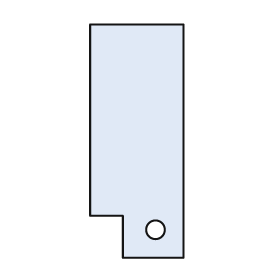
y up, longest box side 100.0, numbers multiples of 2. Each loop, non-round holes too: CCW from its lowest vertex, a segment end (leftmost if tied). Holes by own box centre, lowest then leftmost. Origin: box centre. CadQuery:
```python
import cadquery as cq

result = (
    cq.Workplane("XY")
    .moveTo(-6.0, -50.0)
    .lineTo(20.0, -50.0)
    .lineTo(20.0, 50.0)
    .lineTo(-20.0, 50.0)
    .lineTo(-20.0, -32.0)
    .lineTo(-6.0, -32.0)
    .close()
    .moveTo(8.0, -38.0)
    .circle(4.0)
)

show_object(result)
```